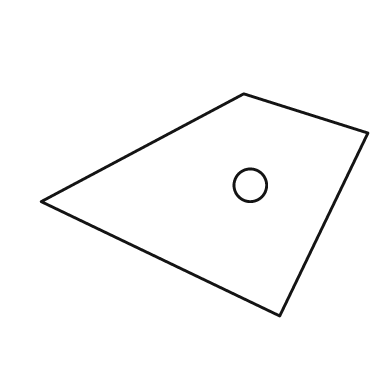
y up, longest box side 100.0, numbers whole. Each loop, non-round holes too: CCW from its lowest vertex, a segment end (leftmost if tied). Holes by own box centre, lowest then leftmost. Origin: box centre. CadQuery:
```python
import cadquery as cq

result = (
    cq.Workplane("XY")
    .moveTo(23.0, -34.0)
    .lineTo(50.0, 22.0)
    .lineTo(12.0, 34.0)
    .lineTo(-50.0, 1.0)
    .close()
    .moveTo(14.0, 6.0)
    .circle(5.0)
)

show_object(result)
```